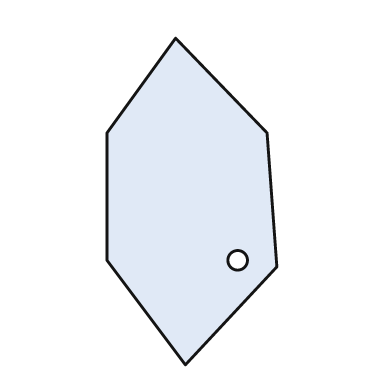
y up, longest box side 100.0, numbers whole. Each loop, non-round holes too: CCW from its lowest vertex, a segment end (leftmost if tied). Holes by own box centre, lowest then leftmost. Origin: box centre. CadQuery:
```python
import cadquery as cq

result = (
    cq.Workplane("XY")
    .moveTo(-2.0, -50.0)
    .lineTo(26.0, -20.0)
    .lineTo(23.0, 21.0)
    .lineTo(-5.0, 50.0)
    .lineTo(-26.0, 21.0)
    .lineTo(-26.0, -18.0)
    .close()
    .moveTo(14.0, -18.0)
    .circle(3.0)
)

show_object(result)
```